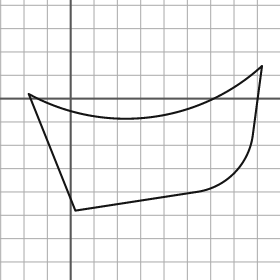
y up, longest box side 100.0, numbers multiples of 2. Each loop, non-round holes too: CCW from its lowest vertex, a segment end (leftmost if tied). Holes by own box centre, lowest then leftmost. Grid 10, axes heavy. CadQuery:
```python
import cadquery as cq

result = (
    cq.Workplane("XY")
    .moveTo(2.0, -48.0)
    .lineTo(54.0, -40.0)
    .threePointArc((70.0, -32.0), (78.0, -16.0))
    .lineTo(82.0, 14.0)
    .threePointArc((34.0, -8.0), (-18.0, 2.0))
    .close()
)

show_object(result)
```